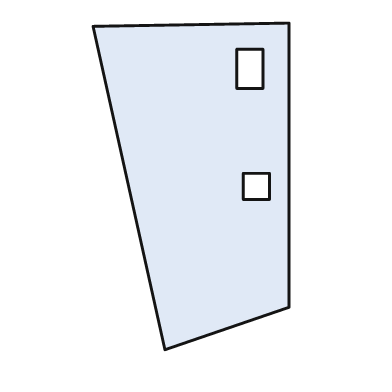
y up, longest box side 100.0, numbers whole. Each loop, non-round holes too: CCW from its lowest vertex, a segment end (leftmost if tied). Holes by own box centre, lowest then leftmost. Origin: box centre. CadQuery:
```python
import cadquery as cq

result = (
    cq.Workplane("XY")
    .moveTo(-8.0, -50.0)
    .lineTo(30.0, -37.0)
    .lineTo(30.0, 50.0)
    .lineTo(-30.0, 49.0)
    .close()
    .moveTo(16.0, -4.0)
    .lineTo(24.0, -4.0)
    .lineTo(24.0, 4.0)
    .lineTo(16.0, 4.0)
    .close()
    .moveTo(14.0, 30.0)
    .lineTo(22.0, 30.0)
    .lineTo(22.0, 42.0)
    .lineTo(14.0, 42.0)
    .close()
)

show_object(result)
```